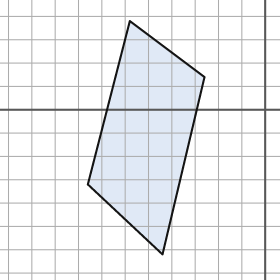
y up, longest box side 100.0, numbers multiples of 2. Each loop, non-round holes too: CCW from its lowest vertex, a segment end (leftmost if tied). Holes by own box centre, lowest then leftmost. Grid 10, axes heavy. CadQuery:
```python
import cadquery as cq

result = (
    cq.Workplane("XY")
    .moveTo(-44.0, -62.0)
    .lineTo(-26.0, 14.0)
    .lineTo(-58.0, 38.0)
    .lineTo(-76.0, -32.0)
    .close()
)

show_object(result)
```